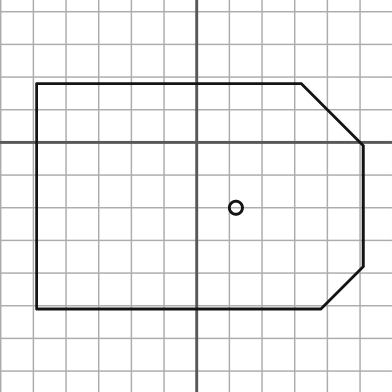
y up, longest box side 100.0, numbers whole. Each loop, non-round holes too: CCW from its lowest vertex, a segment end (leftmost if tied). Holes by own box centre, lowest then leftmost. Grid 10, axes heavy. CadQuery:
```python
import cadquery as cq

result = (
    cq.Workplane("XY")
    .moveTo(-49.0, -51.0)
    .lineTo(38.0, -51.0)
    .lineTo(51.0, -38.0)
    .lineTo(51.0, -1.0)
    .lineTo(32.0, 18.0)
    .lineTo(-49.0, 18.0)
    .close()
    .moveTo(12.0, -20.0)
    .circle(2.0)
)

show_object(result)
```